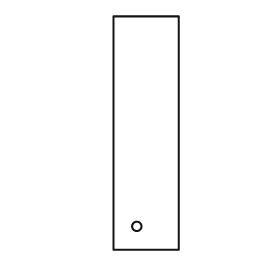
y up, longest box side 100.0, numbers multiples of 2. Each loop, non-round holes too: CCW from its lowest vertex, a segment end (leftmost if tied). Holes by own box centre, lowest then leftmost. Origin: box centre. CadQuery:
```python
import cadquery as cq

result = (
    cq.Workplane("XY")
    .moveTo(-14.0, -50.0)
    .lineTo(14.0, -50.0)
    .lineTo(14.0, 50.0)
    .lineTo(-14.0, 50.0)
    .close()
    .moveTo(-4.0, -40.0)
    .circle(2.0)
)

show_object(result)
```